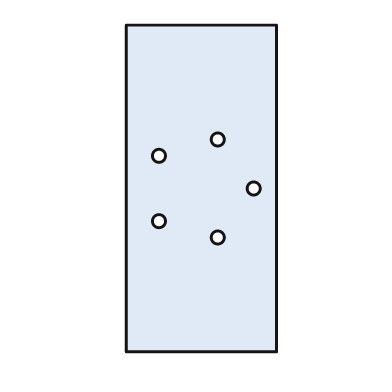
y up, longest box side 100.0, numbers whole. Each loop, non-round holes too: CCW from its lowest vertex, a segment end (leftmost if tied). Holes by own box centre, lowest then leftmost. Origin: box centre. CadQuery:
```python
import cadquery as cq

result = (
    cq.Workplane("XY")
    .moveTo(-23.0, -50.0)
    .lineTo(23.0, -50.0)
    .lineTo(23.0, 50.0)
    .lineTo(-23.0, 50.0)
    .close()
    .moveTo(5.0, -15.0)
    .circle(2.0)
    .moveTo(-13.0, -10.0)
    .circle(2.0)
    .moveTo(16.0, 0.0)
    .circle(2.0)
    .moveTo(-13.0, 10.0)
    .circle(2.0)
    .moveTo(5.0, 15.0)
    .circle(2.0)
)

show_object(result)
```